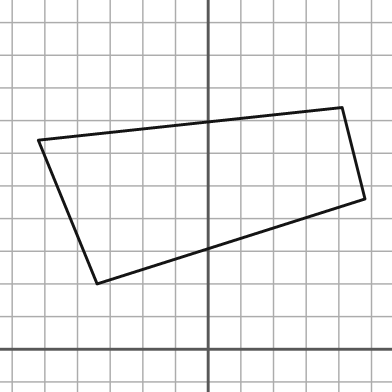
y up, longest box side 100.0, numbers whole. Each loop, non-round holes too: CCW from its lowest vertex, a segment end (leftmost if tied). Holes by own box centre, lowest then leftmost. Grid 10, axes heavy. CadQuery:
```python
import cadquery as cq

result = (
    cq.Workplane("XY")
    .moveTo(-34.0, 20.0)
    .lineTo(48.0, 46.0)
    .lineTo(41.0, 74.0)
    .lineTo(-52.0, 64.0)
    .close()
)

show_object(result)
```